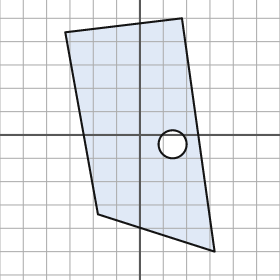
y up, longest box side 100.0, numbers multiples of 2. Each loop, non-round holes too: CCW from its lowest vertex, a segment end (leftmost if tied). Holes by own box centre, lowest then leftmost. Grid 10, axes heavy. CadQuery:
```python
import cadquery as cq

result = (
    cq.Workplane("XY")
    .moveTo(32.0, -50.0)
    .lineTo(18.0, 50.0)
    .lineTo(-32.0, 44.0)
    .lineTo(-18.0, -34.0)
    .close()
    .moveTo(14.0, -4.0)
    .circle(6.0)
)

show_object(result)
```